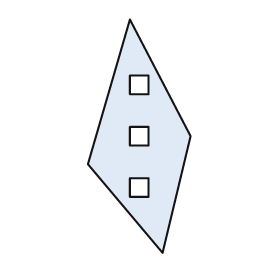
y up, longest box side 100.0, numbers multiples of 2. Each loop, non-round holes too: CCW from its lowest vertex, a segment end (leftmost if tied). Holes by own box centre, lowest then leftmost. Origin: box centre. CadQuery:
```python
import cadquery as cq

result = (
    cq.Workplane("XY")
    .moveTo(10.0, -50.0)
    .lineTo(22.0, 0.0)
    .lineTo(-4.0, 50.0)
    .lineTo(-22.0, -12.0)
    .close()
    .moveTo(-4.0, -26.0)
    .lineTo(4.0, -26.0)
    .lineTo(4.0, -18.0)
    .lineTo(-4.0, -18.0)
    .close()
    .moveTo(-4.0, -4.0)
    .lineTo(4.0, -4.0)
    .lineTo(4.0, 4.0)
    .lineTo(-4.0, 4.0)
    .close()
    .moveTo(-4.0, 18.0)
    .lineTo(4.0, 18.0)
    .lineTo(4.0, 26.0)
    .lineTo(-4.0, 26.0)
    .close()
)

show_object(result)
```